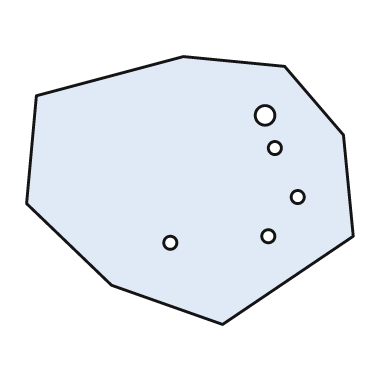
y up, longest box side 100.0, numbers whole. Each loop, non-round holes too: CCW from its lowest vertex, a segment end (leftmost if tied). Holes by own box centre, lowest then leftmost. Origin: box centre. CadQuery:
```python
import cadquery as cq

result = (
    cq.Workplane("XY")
    .moveTo(10.0, -41.0)
    .lineTo(50.0, -14.0)
    .lineTo(47.0, 17.0)
    .lineTo(29.0, 38.0)
    .lineTo(-2.0, 41.0)
    .lineTo(-47.0, 29.0)
    .lineTo(-50.0, -4.0)
    .lineTo(-24.0, -29.0)
    .close()
    .moveTo(-6.0, -16.0)
    .circle(2.0)
    .moveTo(24.0, -14.0)
    .circle(2.0)
    .moveTo(33.0, -2.0)
    .circle(2.0)
    .moveTo(26.0, 13.0)
    .circle(2.0)
    .moveTo(23.0, 23.0)
    .circle(3.0)
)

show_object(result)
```